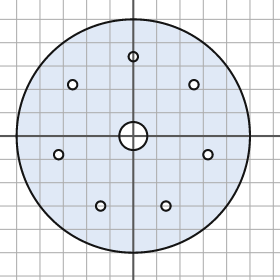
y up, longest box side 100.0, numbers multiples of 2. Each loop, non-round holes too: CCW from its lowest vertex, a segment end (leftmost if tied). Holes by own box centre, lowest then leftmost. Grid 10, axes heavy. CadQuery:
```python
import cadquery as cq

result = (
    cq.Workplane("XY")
    .moveTo(0.0, 0.0)
    .circle(50.0)
    .moveTo(-14.0, -30.0)
    .circle(2.0)
    .moveTo(14.0, -30.0)
    .circle(2.0)
    .moveTo(-32.0, -8.0)
    .circle(2.0)
    .moveTo(32.0, -8.0)
    .circle(2.0)
    .moveTo(0.0, 0.0)
    .circle(6.0)
    .moveTo(-26.0, 22.0)
    .circle(2.0)
    .moveTo(26.0, 22.0)
    .circle(2.0)
    .moveTo(0.0, 34.0)
    .circle(2.0)
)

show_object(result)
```